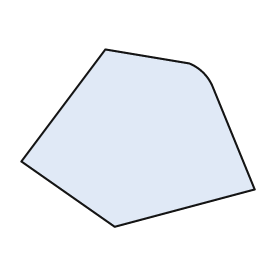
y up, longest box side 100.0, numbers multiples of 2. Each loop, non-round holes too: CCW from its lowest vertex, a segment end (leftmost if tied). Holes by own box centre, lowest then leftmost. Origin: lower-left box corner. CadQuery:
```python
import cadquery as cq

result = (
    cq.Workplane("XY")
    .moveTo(40.0, 0.0)
    .lineTo(100.0, 16.0)
    .lineTo(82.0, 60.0)
    .threePointArc((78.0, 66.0), (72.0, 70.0))
    .lineTo(36.0, 76.0)
    .lineTo(0.0, 28.0)
    .close()
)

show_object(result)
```